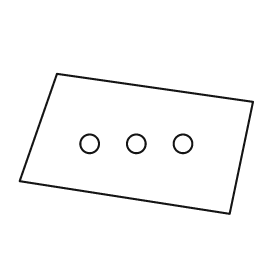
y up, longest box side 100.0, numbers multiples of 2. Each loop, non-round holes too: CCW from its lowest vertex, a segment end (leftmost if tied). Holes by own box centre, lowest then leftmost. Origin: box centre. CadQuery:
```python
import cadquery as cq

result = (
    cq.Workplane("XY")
    .moveTo(40.0, -30.0)
    .lineTo(50.0, 18.0)
    .lineTo(-34.0, 30.0)
    .lineTo(-50.0, -16.0)
    .close()
    .moveTo(-20.0, 0.0)
    .circle(4.0)
    .moveTo(0.0, 0.0)
    .circle(4.0)
    .moveTo(20.0, 0.0)
    .circle(4.0)
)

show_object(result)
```